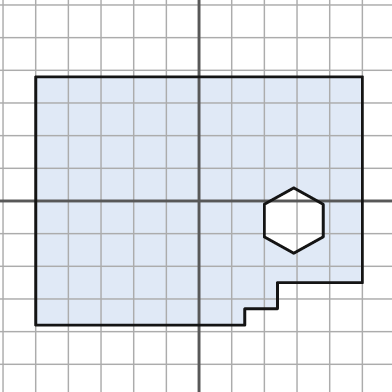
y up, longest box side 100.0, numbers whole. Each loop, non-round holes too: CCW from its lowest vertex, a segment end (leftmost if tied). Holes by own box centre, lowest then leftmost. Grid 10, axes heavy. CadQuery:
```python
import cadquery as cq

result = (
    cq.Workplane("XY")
    .moveTo(-50.0, -38.0)
    .lineTo(14.0, -38.0)
    .lineTo(14.0, -33.0)
    .lineTo(24.0, -33.0)
    .lineTo(24.0, -25.0)
    .lineTo(50.0, -25.0)
    .lineTo(50.0, 38.0)
    .lineTo(-50.0, 38.0)
    .close()
    .moveTo(29.0, -16.0)
    .lineTo(38.0, -11.0)
    .lineTo(38.0, -1.0)
    .lineTo(29.0, 4.0)
    .lineTo(20.0, -1.0)
    .lineTo(20.0, -11.0)
    .close()
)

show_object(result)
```